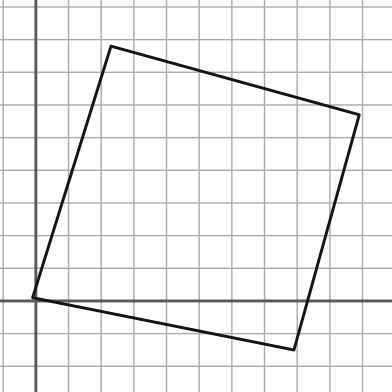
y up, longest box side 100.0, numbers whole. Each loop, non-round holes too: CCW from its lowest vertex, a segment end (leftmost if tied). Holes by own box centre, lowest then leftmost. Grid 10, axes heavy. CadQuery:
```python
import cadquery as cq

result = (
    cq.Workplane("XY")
    .moveTo(79.0, -15.0)
    .lineTo(99.0, 57.0)
    .lineTo(23.0, 78.0)
    .lineTo(-1.0, 1.0)
    .close()
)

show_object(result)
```